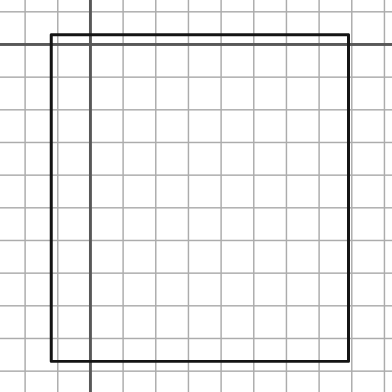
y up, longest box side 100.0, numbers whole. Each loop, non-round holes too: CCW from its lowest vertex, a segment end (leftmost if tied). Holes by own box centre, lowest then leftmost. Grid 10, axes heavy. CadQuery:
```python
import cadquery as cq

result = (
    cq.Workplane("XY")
    .moveTo(-12.0, -97.0)
    .lineTo(79.0, -97.0)
    .lineTo(79.0, 3.0)
    .lineTo(-12.0, 3.0)
    .close()
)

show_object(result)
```